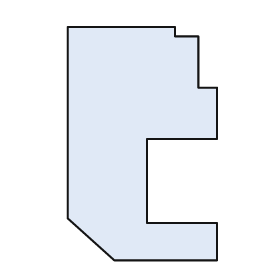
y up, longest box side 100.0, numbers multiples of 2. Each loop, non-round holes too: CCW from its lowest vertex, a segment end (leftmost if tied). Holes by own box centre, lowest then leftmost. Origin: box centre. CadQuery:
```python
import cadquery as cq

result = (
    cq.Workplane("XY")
    .moveTo(-12.0, -50.0)
    .lineTo(32.0, -50.0)
    .lineTo(32.0, -34.0)
    .lineTo(2.0, -34.0)
    .lineTo(2.0, 2.0)
    .lineTo(32.0, 2.0)
    .lineTo(32.0, 24.0)
    .lineTo(24.0, 24.0)
    .lineTo(24.0, 46.0)
    .lineTo(14.0, 46.0)
    .lineTo(14.0, 50.0)
    .lineTo(-32.0, 50.0)
    .lineTo(-32.0, -32.0)
    .close()
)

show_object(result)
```